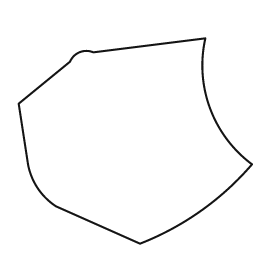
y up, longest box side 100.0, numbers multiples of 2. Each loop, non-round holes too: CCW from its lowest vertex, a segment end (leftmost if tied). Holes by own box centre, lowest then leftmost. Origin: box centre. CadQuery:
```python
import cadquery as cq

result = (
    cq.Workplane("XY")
    .moveTo(2.0, -44.0)
    .threePointArc((28.0, -30.0), (50.0, -10.0))
    .threePointArc((32.0, 14.0), (30.0, 44.0))
    .lineTo(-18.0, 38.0)
    .threePointArc((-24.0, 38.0), (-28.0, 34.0))
    .lineTo(-50.0, 16.0)
    .lineTo(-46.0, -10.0)
    .threePointArc((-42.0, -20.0), (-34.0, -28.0))
    .close()
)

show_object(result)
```